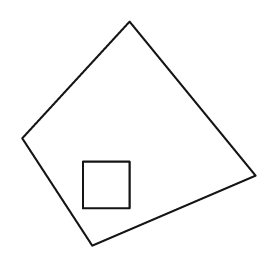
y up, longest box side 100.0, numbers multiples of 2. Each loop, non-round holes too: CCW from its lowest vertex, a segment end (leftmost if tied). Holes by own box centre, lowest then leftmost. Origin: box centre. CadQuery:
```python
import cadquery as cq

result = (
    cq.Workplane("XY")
    .moveTo(-20.0, -48.0)
    .lineTo(50.0, -18.0)
    .lineTo(-4.0, 48.0)
    .lineTo(-50.0, -2.0)
    .close()
    .moveTo(-24.0, -32.0)
    .lineTo(-4.0, -32.0)
    .lineTo(-4.0, -12.0)
    .lineTo(-24.0, -12.0)
    .close()
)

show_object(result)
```